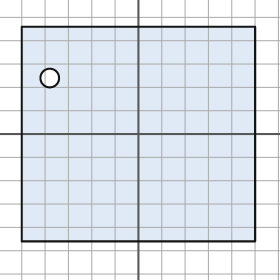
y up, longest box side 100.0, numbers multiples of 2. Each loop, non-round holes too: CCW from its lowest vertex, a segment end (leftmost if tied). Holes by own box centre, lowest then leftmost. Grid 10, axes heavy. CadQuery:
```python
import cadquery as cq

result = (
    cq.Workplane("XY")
    .moveTo(-50.0, -46.0)
    .lineTo(50.0, -46.0)
    .lineTo(50.0, 46.0)
    .lineTo(-50.0, 46.0)
    .close()
    .moveTo(-38.0, 24.0)
    .circle(4.0)
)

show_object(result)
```